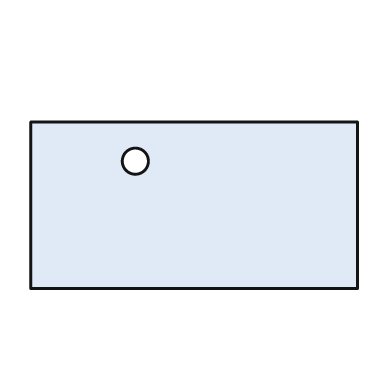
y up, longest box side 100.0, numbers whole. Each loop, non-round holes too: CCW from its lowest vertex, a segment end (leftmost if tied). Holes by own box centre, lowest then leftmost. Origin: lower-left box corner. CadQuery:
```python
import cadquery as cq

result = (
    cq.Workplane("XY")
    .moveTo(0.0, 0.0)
    .lineTo(100.0, 0.0)
    .lineTo(100.0, 51.0)
    .lineTo(0.0, 51.0)
    .close()
    .moveTo(32.0, 39.0)
    .circle(4.0)
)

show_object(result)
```